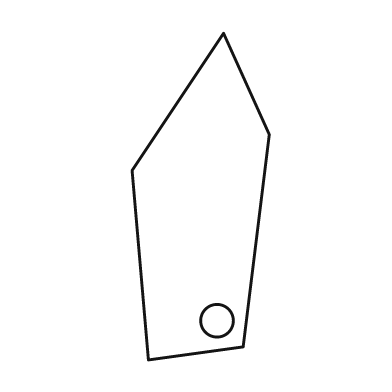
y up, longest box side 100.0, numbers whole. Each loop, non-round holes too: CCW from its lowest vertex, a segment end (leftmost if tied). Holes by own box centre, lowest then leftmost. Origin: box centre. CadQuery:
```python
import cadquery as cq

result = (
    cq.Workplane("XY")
    .moveTo(-16.0, -50.0)
    .lineTo(13.0, -46.0)
    .lineTo(21.0, 19.0)
    .lineTo(7.0, 50.0)
    .lineTo(-21.0, 8.0)
    .close()
    .moveTo(5.0, -38.0)
    .circle(5.0)
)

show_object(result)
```